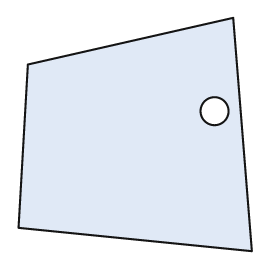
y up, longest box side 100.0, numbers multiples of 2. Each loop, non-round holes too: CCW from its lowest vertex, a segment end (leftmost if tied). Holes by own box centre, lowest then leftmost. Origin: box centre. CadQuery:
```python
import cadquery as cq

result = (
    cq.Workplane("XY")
    .moveTo(50.0, -50.0)
    .lineTo(42.0, 50.0)
    .lineTo(-46.0, 30.0)
    .lineTo(-50.0, -40.0)
    .close()
    .moveTo(34.0, 10.0)
    .circle(6.0)
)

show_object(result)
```